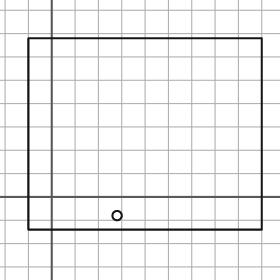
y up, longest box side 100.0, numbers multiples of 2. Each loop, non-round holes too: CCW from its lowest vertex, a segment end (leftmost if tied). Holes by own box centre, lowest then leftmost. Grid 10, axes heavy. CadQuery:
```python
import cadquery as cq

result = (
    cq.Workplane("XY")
    .moveTo(-10.0, -14.0)
    .lineTo(90.0, -14.0)
    .lineTo(90.0, 68.0)
    .lineTo(-10.0, 68.0)
    .close()
    .moveTo(28.0, -8.0)
    .circle(2.0)
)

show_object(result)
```